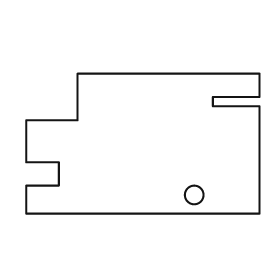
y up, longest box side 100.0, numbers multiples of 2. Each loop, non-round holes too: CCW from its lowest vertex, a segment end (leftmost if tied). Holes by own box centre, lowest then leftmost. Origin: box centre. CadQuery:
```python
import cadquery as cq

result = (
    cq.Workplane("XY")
    .moveTo(-50.0, -30.0)
    .lineTo(50.0, -30.0)
    .lineTo(50.0, 16.0)
    .lineTo(30.0, 16.0)
    .lineTo(30.0, 20.0)
    .lineTo(50.0, 20.0)
    .lineTo(50.0, 30.0)
    .lineTo(-28.0, 30.0)
    .lineTo(-28.0, 10.0)
    .lineTo(-50.0, 10.0)
    .lineTo(-50.0, -8.0)
    .lineTo(-36.0, -8.0)
    .lineTo(-36.0, -18.0)
    .lineTo(-50.0, -18.0)
    .close()
    .moveTo(22.0, -22.0)
    .circle(4.0)
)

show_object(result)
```